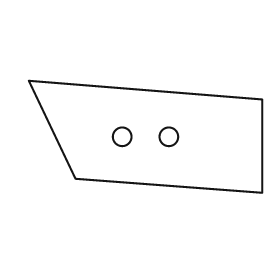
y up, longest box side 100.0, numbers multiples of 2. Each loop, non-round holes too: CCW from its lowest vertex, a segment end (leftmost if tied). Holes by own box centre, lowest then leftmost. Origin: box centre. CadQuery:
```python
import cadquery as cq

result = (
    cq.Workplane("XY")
    .moveTo(50.0, -24.0)
    .lineTo(50.0, 16.0)
    .lineTo(-50.0, 24.0)
    .lineTo(-30.0, -18.0)
    .close()
    .moveTo(-10.0, 0.0)
    .circle(4.0)
    .moveTo(10.0, 0.0)
    .circle(4.0)
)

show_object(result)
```